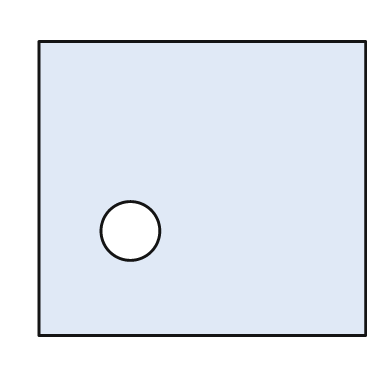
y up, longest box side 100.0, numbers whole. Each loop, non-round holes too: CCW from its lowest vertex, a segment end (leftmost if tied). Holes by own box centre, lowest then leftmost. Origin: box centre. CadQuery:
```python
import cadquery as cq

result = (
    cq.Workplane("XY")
    .moveTo(-50.0, -45.0)
    .lineTo(50.0, -45.0)
    .lineTo(50.0, 45.0)
    .lineTo(-50.0, 45.0)
    .close()
    .moveTo(-22.0, -13.0)
    .circle(9.0)
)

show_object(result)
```